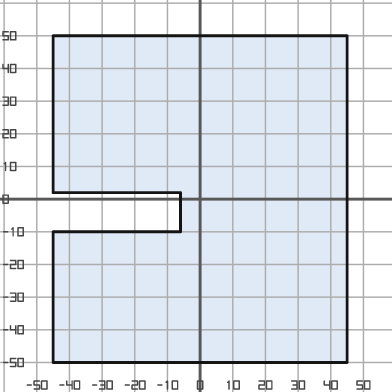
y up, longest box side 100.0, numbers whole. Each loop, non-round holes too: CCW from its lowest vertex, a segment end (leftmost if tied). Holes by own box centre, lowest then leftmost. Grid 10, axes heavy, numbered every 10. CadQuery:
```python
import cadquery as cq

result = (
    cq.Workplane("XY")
    .moveTo(-45.0, -50.0)
    .lineTo(45.0, -50.0)
    .lineTo(45.0, 50.0)
    .lineTo(-45.0, 50.0)
    .lineTo(-45.0, 2.0)
    .lineTo(-6.0, 2.0)
    .lineTo(-6.0, -10.0)
    .lineTo(-45.0, -10.0)
    .close()
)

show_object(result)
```